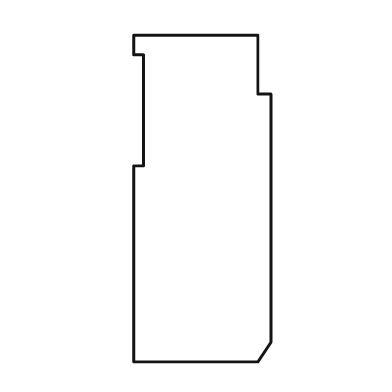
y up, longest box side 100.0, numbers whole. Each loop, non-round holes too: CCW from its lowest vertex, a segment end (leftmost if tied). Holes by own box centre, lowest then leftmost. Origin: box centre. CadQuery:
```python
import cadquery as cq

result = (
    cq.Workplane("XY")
    .moveTo(-21.0, -50.0)
    .lineTo(17.0, -50.0)
    .lineTo(21.0, -44.0)
    .lineTo(21.0, 32.0)
    .lineTo(17.0, 32.0)
    .lineTo(17.0, 50.0)
    .lineTo(-21.0, 50.0)
    .lineTo(-21.0, 44.0)
    .lineTo(-18.0, 44.0)
    .lineTo(-18.0, 10.0)
    .lineTo(-21.0, 10.0)
    .close()
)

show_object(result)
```